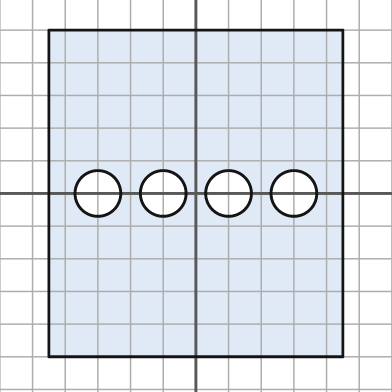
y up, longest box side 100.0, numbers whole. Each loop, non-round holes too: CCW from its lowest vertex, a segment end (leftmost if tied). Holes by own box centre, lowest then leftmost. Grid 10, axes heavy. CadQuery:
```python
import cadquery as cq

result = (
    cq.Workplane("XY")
    .moveTo(-45.0, -50.0)
    .lineTo(45.0, -50.0)
    .lineTo(45.0, 50.0)
    .lineTo(-45.0, 50.0)
    .close()
    .moveTo(-30.0, 0.0)
    .circle(7.0)
    .moveTo(-10.0, 0.0)
    .circle(7.0)
    .moveTo(10.0, 0.0)
    .circle(7.0)
    .moveTo(30.0, 0.0)
    .circle(7.0)
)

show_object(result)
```